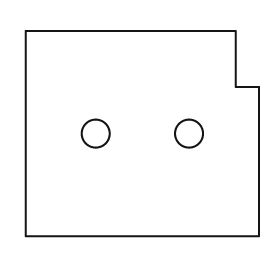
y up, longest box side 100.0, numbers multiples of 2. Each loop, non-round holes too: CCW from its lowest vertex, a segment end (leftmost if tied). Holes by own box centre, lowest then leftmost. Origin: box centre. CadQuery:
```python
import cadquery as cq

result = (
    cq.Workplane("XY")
    .moveTo(-50.0, -44.0)
    .lineTo(50.0, -44.0)
    .lineTo(50.0, 20.0)
    .lineTo(40.0, 20.0)
    .lineTo(40.0, 44.0)
    .lineTo(-50.0, 44.0)
    .close()
    .moveTo(-20.0, 0.0)
    .circle(6.0)
    .moveTo(20.0, 0.0)
    .circle(6.0)
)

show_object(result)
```